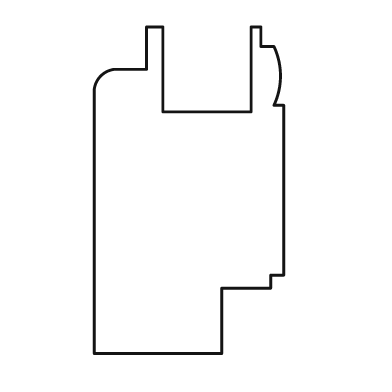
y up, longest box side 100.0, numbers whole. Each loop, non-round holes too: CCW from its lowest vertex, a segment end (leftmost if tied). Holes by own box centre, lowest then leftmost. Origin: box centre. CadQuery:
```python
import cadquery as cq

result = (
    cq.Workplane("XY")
    .moveTo(-29.0, -50.0)
    .lineTo(10.0, -50.0)
    .lineTo(10.0, -30.0)
    .lineTo(25.0, -30.0)
    .lineTo(25.0, -26.0)
    .lineTo(29.0, -26.0)
    .lineTo(29.0, 26.0)
    .lineTo(26.0, 26.0)
    .threePointArc((28.0, 35.0), (26.0, 44.0))
    .lineTo(22.0, 44.0)
    .lineTo(22.0, 50.0)
    .lineTo(19.0, 50.0)
    .lineTo(19.0, 24.0)
    .lineTo(-8.0, 24.0)
    .lineTo(-8.0, 50.0)
    .lineTo(-13.0, 50.0)
    .lineTo(-13.0, 37.0)
    .lineTo(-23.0, 37.0)
    .threePointArc((-27.0, 35.0), (-29.0, 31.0))
    .close()
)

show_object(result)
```